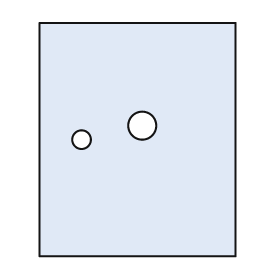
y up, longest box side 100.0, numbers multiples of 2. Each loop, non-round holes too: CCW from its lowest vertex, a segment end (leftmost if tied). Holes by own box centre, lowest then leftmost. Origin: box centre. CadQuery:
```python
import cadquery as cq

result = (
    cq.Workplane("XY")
    .moveTo(-42.0, -50.0)
    .lineTo(42.0, -50.0)
    .lineTo(42.0, 50.0)
    .lineTo(-42.0, 50.0)
    .close()
    .moveTo(-24.0, 0.0)
    .circle(4.0)
    .moveTo(2.0, 6.0)
    .circle(6.0)
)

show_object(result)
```